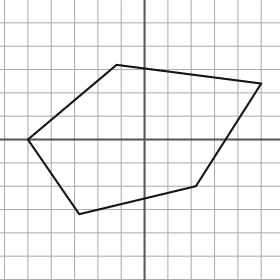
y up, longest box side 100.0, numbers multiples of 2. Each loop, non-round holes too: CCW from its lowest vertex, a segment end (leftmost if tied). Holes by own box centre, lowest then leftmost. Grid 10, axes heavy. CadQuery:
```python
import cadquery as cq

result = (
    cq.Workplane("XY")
    .moveTo(-28.0, -32.0)
    .lineTo(22.0, -20.0)
    .lineTo(50.0, 24.0)
    .lineTo(-12.0, 32.0)
    .lineTo(-50.0, 0.0)
    .close()
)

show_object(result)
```